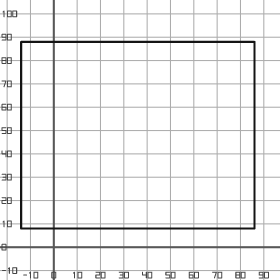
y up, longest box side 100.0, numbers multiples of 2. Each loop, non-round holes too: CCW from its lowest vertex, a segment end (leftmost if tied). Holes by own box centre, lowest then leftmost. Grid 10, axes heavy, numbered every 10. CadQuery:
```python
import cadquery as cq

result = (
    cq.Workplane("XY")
    .moveTo(-14.0, 8.0)
    .lineTo(86.0, 8.0)
    .lineTo(86.0, 88.0)
    .lineTo(-14.0, 88.0)
    .close()
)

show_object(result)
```